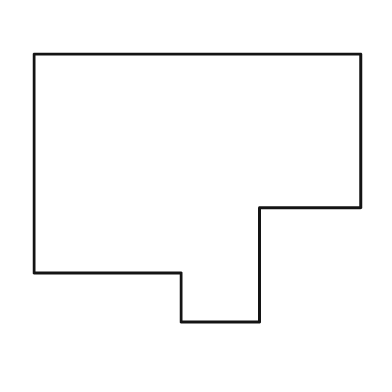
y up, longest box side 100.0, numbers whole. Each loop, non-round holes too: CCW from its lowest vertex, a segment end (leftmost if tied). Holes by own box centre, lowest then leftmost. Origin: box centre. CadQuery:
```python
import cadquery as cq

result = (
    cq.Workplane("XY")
    .moveTo(-5.0, -41.0)
    .lineTo(19.0, -41.0)
    .lineTo(19.0, -6.0)
    .lineTo(50.0, -6.0)
    .lineTo(50.0, 41.0)
    .lineTo(-50.0, 41.0)
    .lineTo(-50.0, -26.0)
    .lineTo(-5.0, -26.0)
    .close()
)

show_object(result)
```